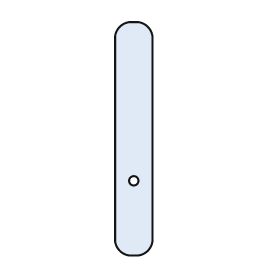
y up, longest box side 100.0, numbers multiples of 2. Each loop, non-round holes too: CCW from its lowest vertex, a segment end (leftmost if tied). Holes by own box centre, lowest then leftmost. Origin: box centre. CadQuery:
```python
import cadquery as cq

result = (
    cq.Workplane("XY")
    .moveTo(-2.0, -50.0)
    .lineTo(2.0, -50.0)
    .threePointArc((6.0, -48.0), (8.0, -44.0))
    .lineTo(8.0, 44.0)
    .threePointArc((6.0, 48.0), (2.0, 50.0))
    .lineTo(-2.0, 50.0)
    .threePointArc((-6.0, 48.0), (-8.0, 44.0))
    .lineTo(-8.0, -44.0)
    .threePointArc((-6.0, -48.0), (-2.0, -50.0))
    .close()
    .moveTo(0.0, -18.0)
    .circle(2.0)
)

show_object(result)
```